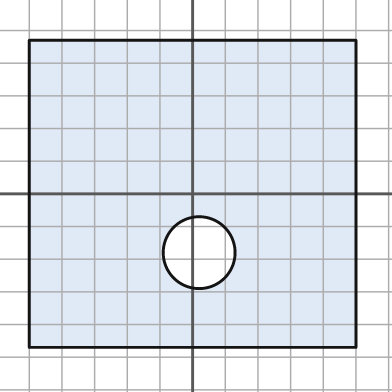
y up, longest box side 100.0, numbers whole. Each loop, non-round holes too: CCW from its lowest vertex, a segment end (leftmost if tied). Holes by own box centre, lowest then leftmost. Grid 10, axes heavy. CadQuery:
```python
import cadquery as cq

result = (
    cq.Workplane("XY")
    .moveTo(-50.0, -47.0)
    .lineTo(50.0, -47.0)
    .lineTo(50.0, 47.0)
    .lineTo(-50.0, 47.0)
    .close()
    .moveTo(2.0, -18.0)
    .circle(11.0)
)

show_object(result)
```